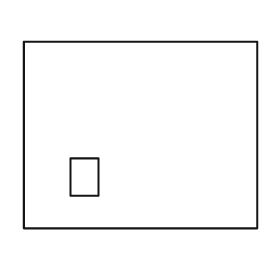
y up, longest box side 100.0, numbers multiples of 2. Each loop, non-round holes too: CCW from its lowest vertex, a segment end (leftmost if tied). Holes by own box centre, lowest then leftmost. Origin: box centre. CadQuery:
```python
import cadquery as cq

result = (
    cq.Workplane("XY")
    .moveTo(-50.0, -40.0)
    .lineTo(50.0, -40.0)
    .lineTo(50.0, 40.0)
    .lineTo(-50.0, 40.0)
    .close()
    .moveTo(-30.0, -26.0)
    .lineTo(-18.0, -26.0)
    .lineTo(-18.0, -10.0)
    .lineTo(-30.0, -10.0)
    .close()
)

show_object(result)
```